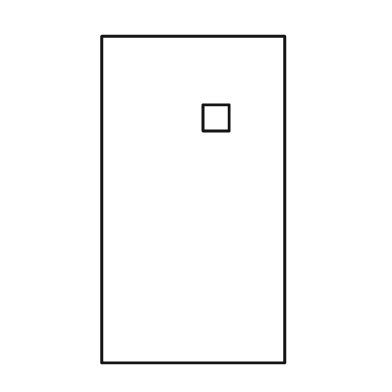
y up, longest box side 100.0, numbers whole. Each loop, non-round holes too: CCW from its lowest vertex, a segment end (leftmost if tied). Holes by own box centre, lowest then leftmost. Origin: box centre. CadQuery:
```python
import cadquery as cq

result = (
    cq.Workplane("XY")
    .moveTo(-28.0, -50.0)
    .lineTo(28.0, -50.0)
    .lineTo(28.0, 50.0)
    .lineTo(-28.0, 50.0)
    .close()
    .moveTo(3.0, 21.0)
    .lineTo(11.0, 21.0)
    .lineTo(11.0, 29.0)
    .lineTo(3.0, 29.0)
    .close()
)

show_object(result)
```